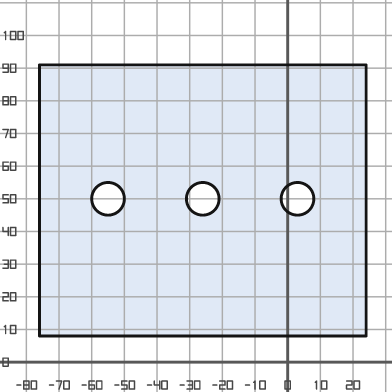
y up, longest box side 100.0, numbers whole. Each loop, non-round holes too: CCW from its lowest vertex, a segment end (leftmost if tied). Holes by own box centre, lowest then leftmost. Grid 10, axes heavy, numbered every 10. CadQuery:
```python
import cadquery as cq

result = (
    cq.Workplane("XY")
    .moveTo(-76.0, 8.0)
    .lineTo(24.0, 8.0)
    .lineTo(24.0, 91.0)
    .lineTo(-76.0, 91.0)
    .close()
    .moveTo(-55.0, 50.0)
    .circle(5.0)
    .moveTo(-26.0, 50.0)
    .circle(5.0)
    .moveTo(3.0, 50.0)
    .circle(5.0)
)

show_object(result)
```